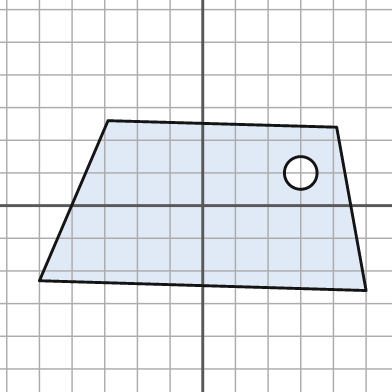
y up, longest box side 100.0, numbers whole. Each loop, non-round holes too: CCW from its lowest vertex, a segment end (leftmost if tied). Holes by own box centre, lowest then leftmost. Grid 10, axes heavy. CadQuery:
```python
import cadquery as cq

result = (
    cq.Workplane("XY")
    .moveTo(50.0, -26.0)
    .lineTo(41.0, 24.0)
    .lineTo(-29.0, 26.0)
    .lineTo(-50.0, -23.0)
    .close()
    .moveTo(30.0, 10.0)
    .circle(5.0)
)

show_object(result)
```